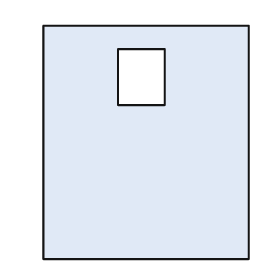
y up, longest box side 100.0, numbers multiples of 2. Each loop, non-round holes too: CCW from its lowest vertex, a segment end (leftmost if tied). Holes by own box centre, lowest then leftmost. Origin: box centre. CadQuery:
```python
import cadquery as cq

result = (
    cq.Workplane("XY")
    .moveTo(-44.0, -50.0)
    .lineTo(44.0, -50.0)
    .lineTo(44.0, 50.0)
    .lineTo(-44.0, 50.0)
    .close()
    .moveTo(-12.0, 16.0)
    .lineTo(8.0, 16.0)
    .lineTo(8.0, 40.0)
    .lineTo(-12.0, 40.0)
    .close()
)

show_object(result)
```